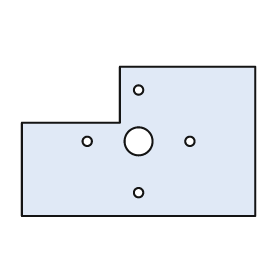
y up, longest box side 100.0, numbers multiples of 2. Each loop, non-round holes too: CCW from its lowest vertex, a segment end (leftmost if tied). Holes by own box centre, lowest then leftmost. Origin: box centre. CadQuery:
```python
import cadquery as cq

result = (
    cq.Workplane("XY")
    .moveTo(-50.0, -32.0)
    .lineTo(50.0, -32.0)
    .lineTo(50.0, 32.0)
    .lineTo(-8.0, 32.0)
    .lineTo(-8.0, 8.0)
    .lineTo(-50.0, 8.0)
    .close()
    .moveTo(0.0, -22.0)
    .circle(2.0)
    .moveTo(-22.0, 0.0)
    .circle(2.0)
    .moveTo(0.0, 0.0)
    .circle(6.0)
    .moveTo(22.0, 0.0)
    .circle(2.0)
    .moveTo(0.0, 22.0)
    .circle(2.0)
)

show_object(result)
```